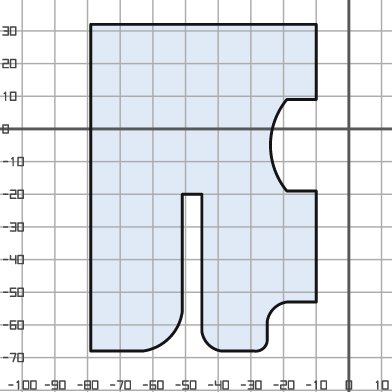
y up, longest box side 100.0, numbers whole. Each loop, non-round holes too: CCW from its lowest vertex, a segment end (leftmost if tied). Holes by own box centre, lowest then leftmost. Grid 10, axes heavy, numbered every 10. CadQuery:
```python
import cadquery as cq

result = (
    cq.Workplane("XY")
    .moveTo(-79.0, -68.0)
    .lineTo(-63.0, -68.0)
    .threePointArc((-55.0, -64.0), (-51.0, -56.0))
    .lineTo(-51.0, -20.0)
    .lineTo(-45.0, -20.0)
    .lineTo(-45.0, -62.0)
    .threePointArc((-43.0, -66.0), (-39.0, -68.0))
    .lineTo(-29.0, -68.0)
    .threePointArc((-26.0, -67.0), (-25.0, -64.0))
    .lineTo(-25.0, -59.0)
    .threePointArc((-23.0, -55.0), (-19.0, -53.0))
    .lineTo(-10.0, -53.0)
    .lineTo(-10.0, -19.0)
    .lineTo(-19.0, -19.0)
    .threePointArc((-24.0, -5.0), (-19.0, 9.0))
    .lineTo(-10.0, 9.0)
    .lineTo(-10.0, 32.0)
    .lineTo(-79.0, 32.0)
    .close()
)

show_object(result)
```